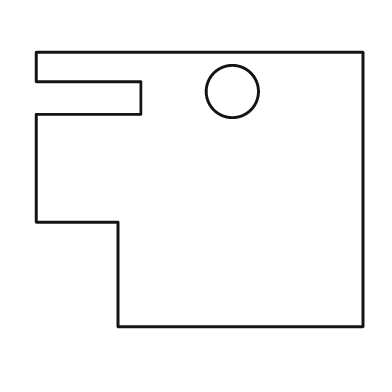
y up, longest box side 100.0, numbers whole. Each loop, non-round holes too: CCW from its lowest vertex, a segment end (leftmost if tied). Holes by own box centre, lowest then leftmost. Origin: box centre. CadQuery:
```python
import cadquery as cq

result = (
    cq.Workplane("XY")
    .moveTo(-25.0, -42.0)
    .lineTo(50.0, -42.0)
    .lineTo(50.0, 42.0)
    .lineTo(-50.0, 42.0)
    .lineTo(-50.0, 33.0)
    .lineTo(-18.0, 33.0)
    .lineTo(-18.0, 23.0)
    .lineTo(-50.0, 23.0)
    .lineTo(-50.0, -10.0)
    .lineTo(-25.0, -10.0)
    .close()
    .moveTo(10.0, 30.0)
    .circle(8.0)
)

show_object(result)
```